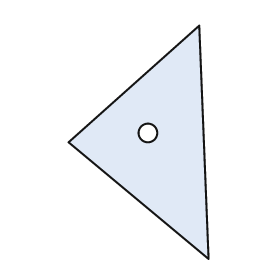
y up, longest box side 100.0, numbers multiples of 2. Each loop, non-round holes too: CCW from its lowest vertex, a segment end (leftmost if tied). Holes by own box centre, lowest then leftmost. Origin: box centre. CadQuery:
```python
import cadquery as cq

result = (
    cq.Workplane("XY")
    .moveTo(30.0, -50.0)
    .lineTo(26.0, 50.0)
    .lineTo(-30.0, 0.0)
    .close()
    .moveTo(4.0, 4.0)
    .circle(4.0)
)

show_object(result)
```